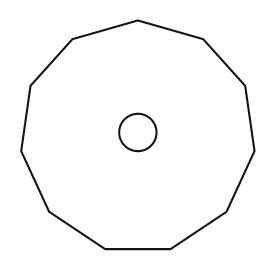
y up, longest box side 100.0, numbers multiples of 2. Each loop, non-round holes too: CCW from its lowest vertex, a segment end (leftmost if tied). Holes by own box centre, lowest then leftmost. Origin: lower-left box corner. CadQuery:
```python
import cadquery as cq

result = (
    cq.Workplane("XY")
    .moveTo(36.0, 0.0)
    .lineTo(64.0, 0.0)
    .lineTo(88.0, 16.0)
    .lineTo(100.0, 42.0)
    .lineTo(96.0, 70.0)
    .lineTo(78.0, 90.0)
    .lineTo(50.0, 98.0)
    .lineTo(22.0, 90.0)
    .lineTo(4.0, 70.0)
    .lineTo(0.0, 42.0)
    .lineTo(12.0, 16.0)
    .close()
    .moveTo(50.0, 50.0)
    .circle(8.0)
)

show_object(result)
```